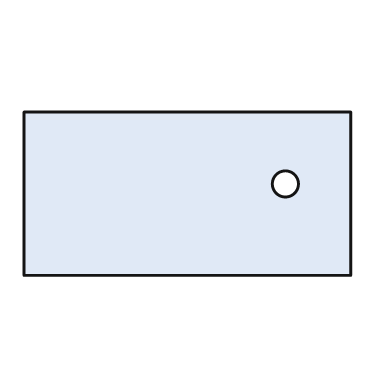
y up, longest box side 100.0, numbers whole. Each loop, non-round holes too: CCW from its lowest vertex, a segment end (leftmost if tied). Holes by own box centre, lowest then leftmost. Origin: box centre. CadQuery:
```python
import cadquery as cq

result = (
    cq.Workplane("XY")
    .moveTo(-50.0, -25.0)
    .lineTo(50.0, -25.0)
    .lineTo(50.0, 25.0)
    .lineTo(-50.0, 25.0)
    .close()
    .moveTo(30.0, 3.0)
    .circle(4.0)
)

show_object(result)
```